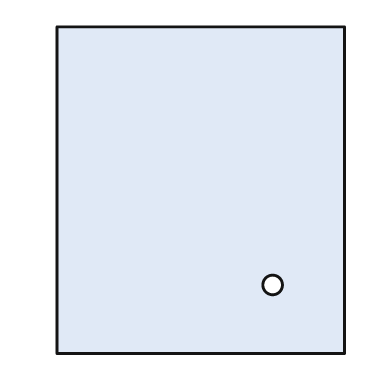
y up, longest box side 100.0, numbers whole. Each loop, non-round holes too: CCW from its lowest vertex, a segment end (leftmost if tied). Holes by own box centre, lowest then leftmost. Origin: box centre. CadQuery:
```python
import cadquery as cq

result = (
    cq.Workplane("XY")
    .moveTo(-44.0, -50.0)
    .lineTo(44.0, -50.0)
    .lineTo(44.0, 50.0)
    .lineTo(-44.0, 50.0)
    .close()
    .moveTo(22.0, -29.0)
    .circle(3.0)
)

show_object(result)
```